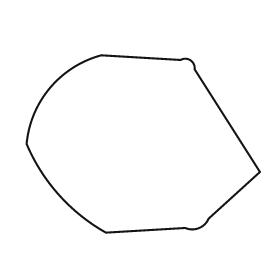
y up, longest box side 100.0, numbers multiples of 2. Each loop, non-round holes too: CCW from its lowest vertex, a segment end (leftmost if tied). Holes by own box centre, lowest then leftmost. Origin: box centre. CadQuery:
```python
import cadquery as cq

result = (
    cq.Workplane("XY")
    .moveTo(-16.0, -38.0)
    .lineTo(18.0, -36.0)
    .threePointArc((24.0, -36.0), (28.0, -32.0))
    .lineTo(50.0, -12.0)
    .lineTo(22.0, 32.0)
    .threePointArc((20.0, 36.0), (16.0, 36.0))
    .lineTo(-18.0, 38.0)
    .threePointArc((-40.0, 24.0), (-50.0, 0.0))
    .threePointArc((-36.0, -22.0), (-16.0, -38.0))
    .close()
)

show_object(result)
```